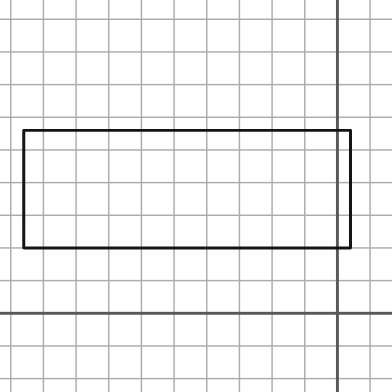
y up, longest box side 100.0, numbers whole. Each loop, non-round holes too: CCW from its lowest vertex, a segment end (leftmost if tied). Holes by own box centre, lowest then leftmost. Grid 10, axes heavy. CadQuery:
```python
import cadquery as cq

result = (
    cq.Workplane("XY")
    .moveTo(-96.0, 20.0)
    .lineTo(4.0, 20.0)
    .lineTo(4.0, 56.0)
    .lineTo(-96.0, 56.0)
    .close()
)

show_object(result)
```